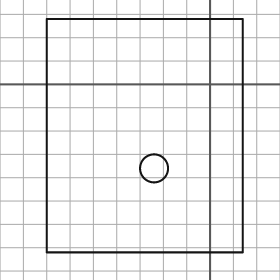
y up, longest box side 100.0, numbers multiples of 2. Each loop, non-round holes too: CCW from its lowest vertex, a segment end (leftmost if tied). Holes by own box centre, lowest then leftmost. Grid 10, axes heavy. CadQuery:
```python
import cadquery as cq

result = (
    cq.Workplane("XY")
    .moveTo(-70.0, -72.0)
    .lineTo(14.0, -72.0)
    .lineTo(14.0, 28.0)
    .lineTo(-70.0, 28.0)
    .close()
    .moveTo(-24.0, -36.0)
    .circle(6.0)
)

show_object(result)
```